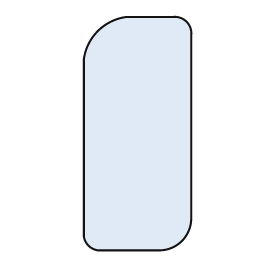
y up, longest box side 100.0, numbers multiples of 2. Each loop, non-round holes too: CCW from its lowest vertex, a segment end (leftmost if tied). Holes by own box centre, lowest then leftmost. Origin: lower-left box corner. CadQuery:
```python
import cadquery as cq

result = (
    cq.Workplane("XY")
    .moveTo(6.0, 0.0)
    .lineTo(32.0, 0.0)
    .threePointArc((42.0, 4.0), (46.0, 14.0))
    .lineTo(46.0, 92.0)
    .threePointArc((44.0, 98.0), (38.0, 100.0))
    .lineTo(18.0, 100.0)
    .threePointArc((6.0, 94.0), (0.0, 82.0))
    .lineTo(0.0, 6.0)
    .threePointArc((2.0, 2.0), (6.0, 0.0))
    .close()
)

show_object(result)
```